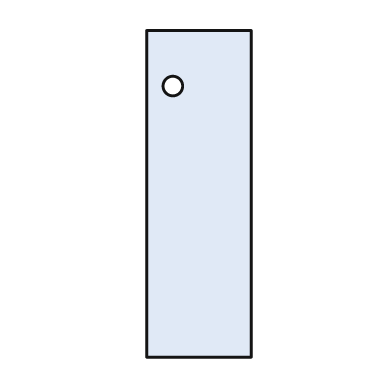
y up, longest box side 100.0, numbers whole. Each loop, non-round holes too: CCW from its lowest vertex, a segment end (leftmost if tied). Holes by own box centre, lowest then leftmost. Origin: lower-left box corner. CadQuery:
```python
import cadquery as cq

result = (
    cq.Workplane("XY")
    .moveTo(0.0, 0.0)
    .lineTo(32.0, 0.0)
    .lineTo(32.0, 100.0)
    .lineTo(0.0, 100.0)
    .close()
    .moveTo(8.0, 83.0)
    .circle(3.0)
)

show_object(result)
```